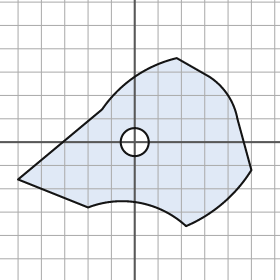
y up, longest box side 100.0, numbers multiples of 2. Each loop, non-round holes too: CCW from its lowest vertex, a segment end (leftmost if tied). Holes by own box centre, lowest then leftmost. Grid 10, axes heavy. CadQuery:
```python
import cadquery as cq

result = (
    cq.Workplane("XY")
    .moveTo(22.0, -36.0)
    .threePointArc((38.0, -26.0), (50.0, -12.0))
    .lineTo(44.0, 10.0)
    .threePointArc((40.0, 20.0), (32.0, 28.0))
    .lineTo(18.0, 36.0)
    .threePointArc((0.0, 28.0), (-14.0, 14.0))
    .lineTo(-50.0, -16.0)
    .lineTo(-20.0, -28.0)
    .threePointArc((2.0, -26.0), (22.0, -36.0))
    .close()
    .moveTo(0.0, 0.0)
    .circle(6.0)
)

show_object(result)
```